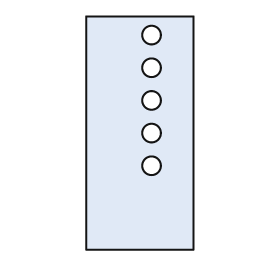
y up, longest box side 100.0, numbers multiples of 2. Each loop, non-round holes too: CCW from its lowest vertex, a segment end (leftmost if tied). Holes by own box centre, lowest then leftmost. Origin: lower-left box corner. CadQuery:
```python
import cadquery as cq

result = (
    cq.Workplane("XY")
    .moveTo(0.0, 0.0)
    .lineTo(46.0, 0.0)
    .lineTo(46.0, 100.0)
    .lineTo(0.0, 100.0)
    .close()
    .moveTo(28.0, 36.0)
    .circle(4.0)
    .moveTo(28.0, 50.0)
    .circle(4.0)
    .moveTo(28.0, 64.0)
    .circle(4.0)
    .moveTo(28.0, 78.0)
    .circle(4.0)
    .moveTo(28.0, 92.0)
    .circle(4.0)
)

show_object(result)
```